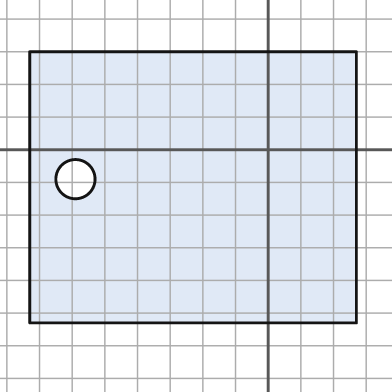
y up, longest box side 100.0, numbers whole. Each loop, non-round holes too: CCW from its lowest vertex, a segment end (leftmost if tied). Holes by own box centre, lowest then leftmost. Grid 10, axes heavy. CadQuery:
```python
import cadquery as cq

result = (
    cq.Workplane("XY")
    .moveTo(-73.0, -53.0)
    .lineTo(27.0, -53.0)
    .lineTo(27.0, 30.0)
    .lineTo(-73.0, 30.0)
    .close()
    .moveTo(-59.0, -9.0)
    .circle(6.0)
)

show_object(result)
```